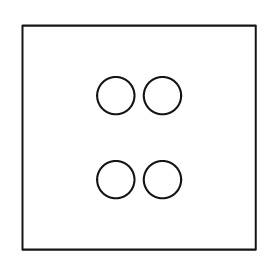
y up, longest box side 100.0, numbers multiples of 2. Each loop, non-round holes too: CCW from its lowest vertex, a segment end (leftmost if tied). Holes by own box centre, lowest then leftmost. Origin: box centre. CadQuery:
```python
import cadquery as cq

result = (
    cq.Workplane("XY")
    .moveTo(-50.0, -48.0)
    .lineTo(50.0, -48.0)
    .lineTo(50.0, 48.0)
    .lineTo(-50.0, 48.0)
    .close()
    .moveTo(-10.0, -18.0)
    .circle(8.0)
    .moveTo(10.0, -18.0)
    .circle(8.0)
    .moveTo(-10.0, 18.0)
    .circle(8.0)
    .moveTo(10.0, 18.0)
    .circle(8.0)
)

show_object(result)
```